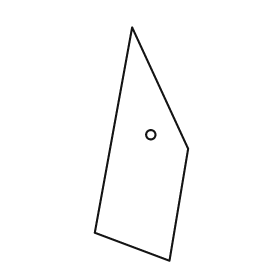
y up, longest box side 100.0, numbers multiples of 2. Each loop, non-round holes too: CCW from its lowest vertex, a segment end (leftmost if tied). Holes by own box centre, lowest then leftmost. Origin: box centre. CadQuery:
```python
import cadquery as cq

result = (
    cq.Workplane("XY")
    .moveTo(12.0, -50.0)
    .lineTo(20.0, -2.0)
    .lineTo(-4.0, 50.0)
    .lineTo(-20.0, -38.0)
    .close()
    .moveTo(4.0, 4.0)
    .circle(2.0)
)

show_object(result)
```